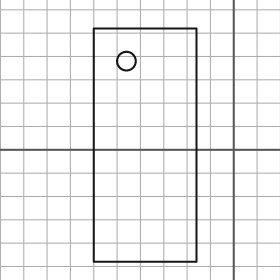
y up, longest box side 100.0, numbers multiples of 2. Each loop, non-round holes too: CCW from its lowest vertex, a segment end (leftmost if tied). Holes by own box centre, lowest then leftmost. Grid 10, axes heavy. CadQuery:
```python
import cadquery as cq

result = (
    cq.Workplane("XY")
    .moveTo(-60.0, -48.0)
    .lineTo(-16.0, -48.0)
    .lineTo(-16.0, 52.0)
    .lineTo(-60.0, 52.0)
    .close()
    .moveTo(-46.0, 38.0)
    .circle(4.0)
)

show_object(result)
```